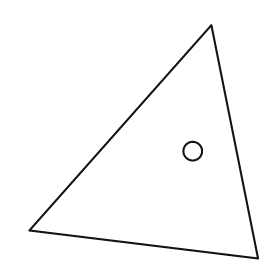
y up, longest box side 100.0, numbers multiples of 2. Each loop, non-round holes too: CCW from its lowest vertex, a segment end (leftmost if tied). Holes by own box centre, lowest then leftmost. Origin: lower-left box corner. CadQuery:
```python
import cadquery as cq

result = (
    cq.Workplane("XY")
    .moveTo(98.0, 0.0)
    .lineTo(78.0, 100.0)
    .lineTo(0.0, 12.0)
    .close()
    .moveTo(70.0, 46.0)
    .circle(4.0)
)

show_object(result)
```